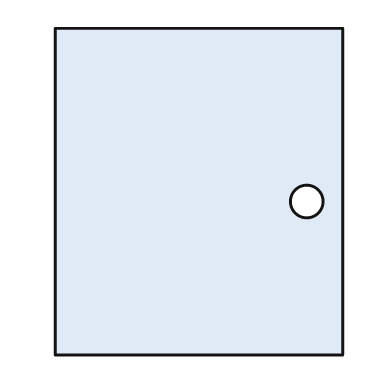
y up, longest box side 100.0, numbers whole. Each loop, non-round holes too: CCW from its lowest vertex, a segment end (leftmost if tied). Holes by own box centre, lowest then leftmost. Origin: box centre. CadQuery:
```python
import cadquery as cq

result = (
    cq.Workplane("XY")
    .moveTo(-44.0, -50.0)
    .lineTo(44.0, -50.0)
    .lineTo(44.0, 50.0)
    .lineTo(-44.0, 50.0)
    .close()
    .moveTo(33.0, -3.0)
    .circle(5.0)
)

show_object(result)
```